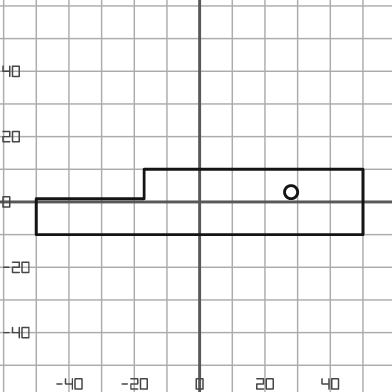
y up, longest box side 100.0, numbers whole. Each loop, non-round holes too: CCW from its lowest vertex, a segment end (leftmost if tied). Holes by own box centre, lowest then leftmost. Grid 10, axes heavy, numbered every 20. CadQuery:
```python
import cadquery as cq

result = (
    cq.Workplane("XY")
    .moveTo(-50.0, -10.0)
    .lineTo(50.0, -10.0)
    .lineTo(50.0, 10.0)
    .lineTo(-17.0, 10.0)
    .lineTo(-17.0, 1.0)
    .lineTo(-50.0, 1.0)
    .close()
    .moveTo(28.0, 3.0)
    .circle(2.0)
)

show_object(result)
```